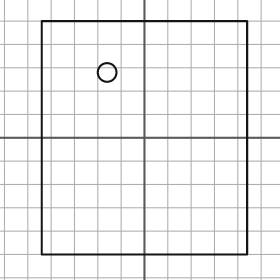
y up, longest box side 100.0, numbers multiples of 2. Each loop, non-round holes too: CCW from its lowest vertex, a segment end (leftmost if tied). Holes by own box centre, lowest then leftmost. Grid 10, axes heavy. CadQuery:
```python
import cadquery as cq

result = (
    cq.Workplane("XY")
    .moveTo(-44.0, -50.0)
    .lineTo(44.0, -50.0)
    .lineTo(44.0, 50.0)
    .lineTo(-44.0, 50.0)
    .close()
    .moveTo(-16.0, 28.0)
    .circle(4.0)
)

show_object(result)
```